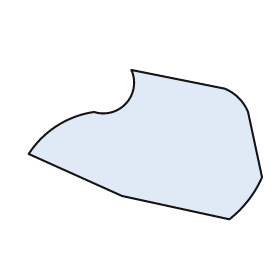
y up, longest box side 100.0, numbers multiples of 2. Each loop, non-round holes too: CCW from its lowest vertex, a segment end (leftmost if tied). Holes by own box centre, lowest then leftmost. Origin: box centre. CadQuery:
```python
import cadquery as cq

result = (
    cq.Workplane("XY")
    .moveTo(36.0, -32.0)
    .threePointArc((44.0, -24.0), (50.0, -14.0))
    .lineTo(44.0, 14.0)
    .threePointArc((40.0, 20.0), (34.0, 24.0))
    .lineTo(-6.0, 32.0)
    .threePointArc((-8.0, 18.0), (-22.0, 14.0))
    .threePointArc((-38.0, 8.0), (-50.0, -4.0))
    .lineTo(-10.0, -22.0)
    .close()
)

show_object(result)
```